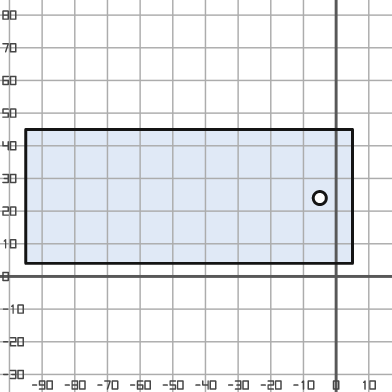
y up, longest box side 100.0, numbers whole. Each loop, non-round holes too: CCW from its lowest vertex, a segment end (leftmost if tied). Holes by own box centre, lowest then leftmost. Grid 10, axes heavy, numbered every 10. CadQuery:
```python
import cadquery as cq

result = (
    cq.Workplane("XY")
    .moveTo(-95.0, 4.0)
    .lineTo(5.0, 4.0)
    .lineTo(5.0, 45.0)
    .lineTo(-95.0, 45.0)
    .close()
    .moveTo(-5.0, 24.0)
    .circle(2.0)
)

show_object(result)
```